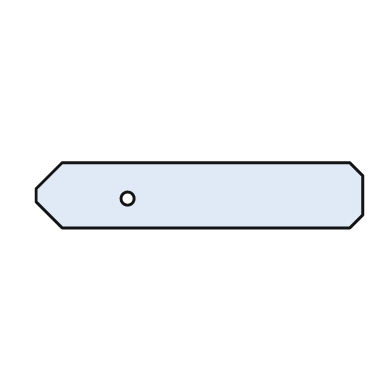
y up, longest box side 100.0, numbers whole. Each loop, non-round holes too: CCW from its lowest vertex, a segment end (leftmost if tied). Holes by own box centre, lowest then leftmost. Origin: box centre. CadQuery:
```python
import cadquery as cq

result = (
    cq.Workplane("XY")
    .moveTo(-42.0, -10.0)
    .lineTo(46.0, -10.0)
    .lineTo(50.0, -6.0)
    .lineTo(50.0, 6.0)
    .lineTo(46.0, 10.0)
    .lineTo(-42.0, 10.0)
    .lineTo(-50.0, 2.0)
    .lineTo(-50.0, -2.0)
    .close()
    .moveTo(-22.0, -1.0)
    .circle(2.0)
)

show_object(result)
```